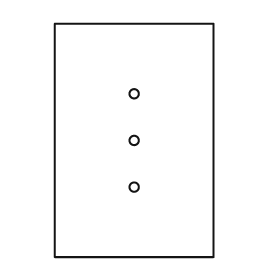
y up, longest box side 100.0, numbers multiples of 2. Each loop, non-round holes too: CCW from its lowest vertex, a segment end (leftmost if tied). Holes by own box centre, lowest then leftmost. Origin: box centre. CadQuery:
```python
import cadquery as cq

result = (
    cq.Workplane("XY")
    .moveTo(-34.0, -50.0)
    .lineTo(34.0, -50.0)
    .lineTo(34.0, 50.0)
    .lineTo(-34.0, 50.0)
    .close()
    .moveTo(0.0, -20.0)
    .circle(2.0)
    .moveTo(0.0, 0.0)
    .circle(2.0)
    .moveTo(0.0, 20.0)
    .circle(2.0)
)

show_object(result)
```